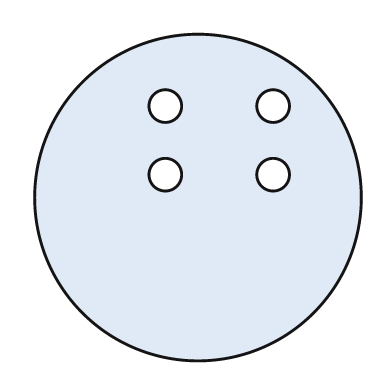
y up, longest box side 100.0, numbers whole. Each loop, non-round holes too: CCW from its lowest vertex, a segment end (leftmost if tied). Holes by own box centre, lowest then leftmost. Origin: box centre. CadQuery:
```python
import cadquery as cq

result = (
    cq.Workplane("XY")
    .moveTo(0.0, 0.0)
    .circle(50.0)
    .moveTo(-10.0, 7.0)
    .circle(5.0)
    .moveTo(23.0, 7.0)
    .circle(5.0)
    .moveTo(-10.0, 28.0)
    .circle(5.0)
    .moveTo(23.0, 28.0)
    .circle(5.0)
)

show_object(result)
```